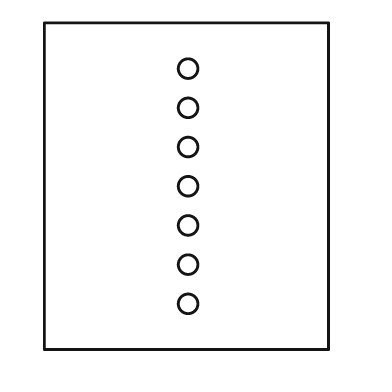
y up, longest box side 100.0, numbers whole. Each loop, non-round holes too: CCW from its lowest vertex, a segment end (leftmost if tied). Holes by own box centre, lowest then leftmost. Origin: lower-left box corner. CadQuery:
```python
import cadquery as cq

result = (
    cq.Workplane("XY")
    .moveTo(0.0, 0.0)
    .lineTo(87.0, 0.0)
    .lineTo(87.0, 100.0)
    .lineTo(0.0, 100.0)
    .close()
    .moveTo(44.0, 14.0)
    .circle(3.0)
    .moveTo(44.0, 26.0)
    .circle(3.0)
    .moveTo(44.0, 38.0)
    .circle(3.0)
    .moveTo(44.0, 50.0)
    .circle(3.0)
    .moveTo(44.0, 62.0)
    .circle(3.0)
    .moveTo(44.0, 74.0)
    .circle(3.0)
    .moveTo(44.0, 86.0)
    .circle(3.0)
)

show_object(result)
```